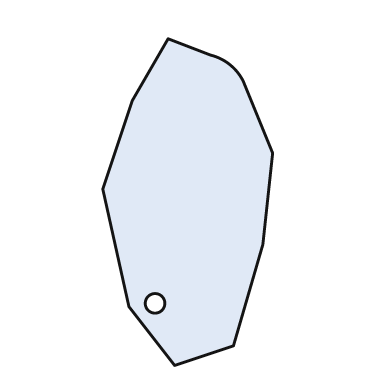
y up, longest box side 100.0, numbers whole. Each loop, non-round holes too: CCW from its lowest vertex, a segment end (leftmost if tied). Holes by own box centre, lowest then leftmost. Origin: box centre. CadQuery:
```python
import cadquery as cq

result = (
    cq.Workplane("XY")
    .moveTo(-4.0, -50.0)
    .lineTo(14.0, -44.0)
    .lineTo(23.0, -13.0)
    .lineTo(26.0, 15.0)
    .lineTo(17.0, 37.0)
    .threePointArc((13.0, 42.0), (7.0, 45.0))
    .lineTo(-6.0, 50.0)
    .lineTo(-17.0, 31.0)
    .lineTo(-26.0, 4.0)
    .lineTo(-18.0, -32.0)
    .close()
    .moveTo(-10.0, -31.0)
    .circle(3.0)
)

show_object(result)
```